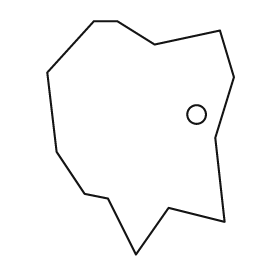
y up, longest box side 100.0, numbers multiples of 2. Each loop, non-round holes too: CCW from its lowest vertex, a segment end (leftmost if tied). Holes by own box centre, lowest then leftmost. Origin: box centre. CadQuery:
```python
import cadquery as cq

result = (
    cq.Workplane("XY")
    .moveTo(-2.0, -50.0)
    .lineTo(12.0, -30.0)
    .lineTo(36.0, -36.0)
    .lineTo(32.0, 0.0)
    .lineTo(40.0, 26.0)
    .lineTo(34.0, 46.0)
    .lineTo(6.0, 40.0)
    .lineTo(-10.0, 50.0)
    .lineTo(-20.0, 50.0)
    .lineTo(-40.0, 28.0)
    .lineTo(-36.0, -6.0)
    .lineTo(-24.0, -24.0)
    .lineTo(-14.0, -26.0)
    .close()
    .moveTo(24.0, 10.0)
    .circle(4.0)
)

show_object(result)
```